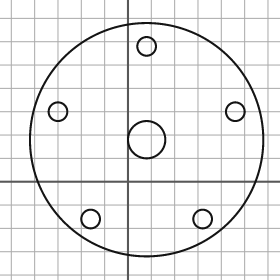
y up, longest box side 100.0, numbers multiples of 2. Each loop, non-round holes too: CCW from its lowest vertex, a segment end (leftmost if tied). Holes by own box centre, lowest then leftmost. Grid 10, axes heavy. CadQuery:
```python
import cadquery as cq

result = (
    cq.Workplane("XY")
    .moveTo(8.0, 18.0)
    .circle(50.0)
    .moveTo(-16.0, -16.0)
    .circle(4.0)
    .moveTo(32.0, -16.0)
    .circle(4.0)
    .moveTo(8.0, 18.0)
    .circle(8.0)
    .moveTo(-30.0, 30.0)
    .circle(4.0)
    .moveTo(46.0, 30.0)
    .circle(4.0)
    .moveTo(8.0, 58.0)
    .circle(4.0)
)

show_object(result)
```